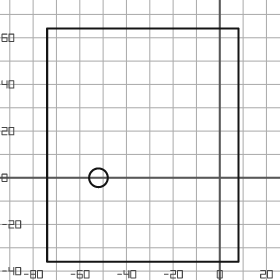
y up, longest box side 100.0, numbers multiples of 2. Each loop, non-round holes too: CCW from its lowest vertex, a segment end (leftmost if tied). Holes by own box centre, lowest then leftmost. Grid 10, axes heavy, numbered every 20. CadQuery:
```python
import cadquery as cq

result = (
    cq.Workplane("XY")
    .moveTo(-74.0, -36.0)
    .lineTo(8.0, -36.0)
    .lineTo(8.0, 64.0)
    .lineTo(-74.0, 64.0)
    .close()
    .moveTo(-52.0, 0.0)
    .circle(4.0)
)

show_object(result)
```